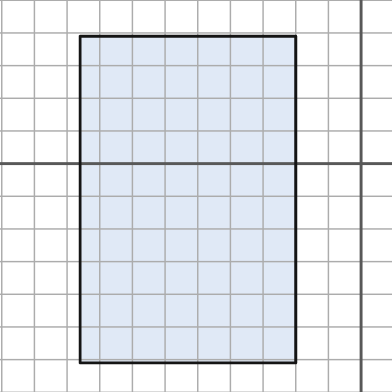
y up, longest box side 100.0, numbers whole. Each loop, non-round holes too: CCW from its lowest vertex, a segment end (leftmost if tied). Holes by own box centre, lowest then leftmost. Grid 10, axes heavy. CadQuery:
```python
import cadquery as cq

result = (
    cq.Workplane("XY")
    .moveTo(-86.0, -61.0)
    .lineTo(-20.0, -61.0)
    .lineTo(-20.0, 39.0)
    .lineTo(-86.0, 39.0)
    .close()
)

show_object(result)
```